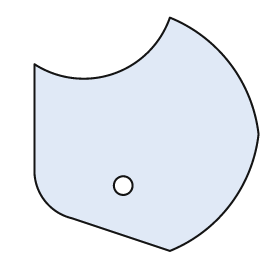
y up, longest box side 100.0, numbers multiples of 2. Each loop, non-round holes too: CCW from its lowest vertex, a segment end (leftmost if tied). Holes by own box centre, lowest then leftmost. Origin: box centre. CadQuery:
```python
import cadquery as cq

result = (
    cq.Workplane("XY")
    .moveTo(10.0, -50.0)
    .threePointArc((36.0, -30.0), (48.0, 0.0))
    .threePointArc((36.0, 30.0), (10.0, 50.0))
    .threePointArc((-14.0, 26.0), (-48.0, 30.0))
    .lineTo(-48.0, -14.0)
    .threePointArc((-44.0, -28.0), (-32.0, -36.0))
    .close()
    .moveTo(-10.0, -22.0)
    .circle(4.0)
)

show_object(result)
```